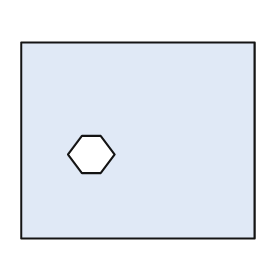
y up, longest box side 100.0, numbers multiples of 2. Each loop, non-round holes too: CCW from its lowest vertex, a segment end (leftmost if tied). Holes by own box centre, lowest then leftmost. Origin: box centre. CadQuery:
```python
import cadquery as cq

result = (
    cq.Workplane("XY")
    .moveTo(-50.0, -42.0)
    .lineTo(50.0, -42.0)
    .lineTo(50.0, 42.0)
    .lineTo(-50.0, 42.0)
    .close()
    .moveTo(-24.0, -14.0)
    .lineTo(-16.0, -14.0)
    .lineTo(-10.0, -6.0)
    .lineTo(-16.0, 2.0)
    .lineTo(-24.0, 2.0)
    .lineTo(-30.0, -6.0)
    .close()
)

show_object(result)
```